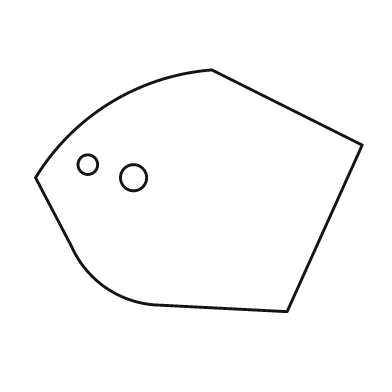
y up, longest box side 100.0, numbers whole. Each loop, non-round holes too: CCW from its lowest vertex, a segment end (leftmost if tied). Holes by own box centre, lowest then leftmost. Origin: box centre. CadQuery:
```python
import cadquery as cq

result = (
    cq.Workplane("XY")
    .moveTo(27.0, -37.0)
    .lineTo(50.0, 14.0)
    .lineTo(4.0, 37.0)
    .threePointArc((-27.0, 27.0), (-50.0, 4.0))
    .lineTo(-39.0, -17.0)
    .threePointArc((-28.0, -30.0), (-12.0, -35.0))
    .close()
    .moveTo(-20.0, 4.0)
    .circle(4.0)
    .moveTo(-34.0, 8.0)
    .circle(3.0)
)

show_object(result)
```